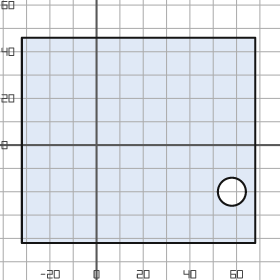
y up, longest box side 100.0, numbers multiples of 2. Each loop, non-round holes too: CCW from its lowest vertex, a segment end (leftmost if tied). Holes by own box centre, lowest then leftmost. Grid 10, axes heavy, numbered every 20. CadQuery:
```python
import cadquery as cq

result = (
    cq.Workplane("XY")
    .moveTo(-32.0, -42.0)
    .lineTo(68.0, -42.0)
    .lineTo(68.0, 46.0)
    .lineTo(-32.0, 46.0)
    .close()
    .moveTo(58.0, -20.0)
    .circle(6.0)
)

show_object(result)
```